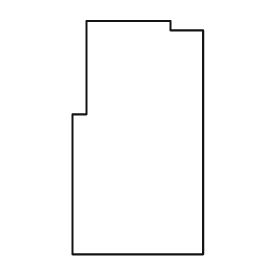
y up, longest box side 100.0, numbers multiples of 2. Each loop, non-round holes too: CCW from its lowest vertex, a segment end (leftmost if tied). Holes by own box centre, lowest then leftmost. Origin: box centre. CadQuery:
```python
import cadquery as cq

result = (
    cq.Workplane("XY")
    .moveTo(-28.0, -50.0)
    .lineTo(28.0, -50.0)
    .lineTo(28.0, 46.0)
    .lineTo(14.0, 46.0)
    .lineTo(14.0, 50.0)
    .lineTo(-22.0, 50.0)
    .lineTo(-22.0, 10.0)
    .lineTo(-28.0, 10.0)
    .close()
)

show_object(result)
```